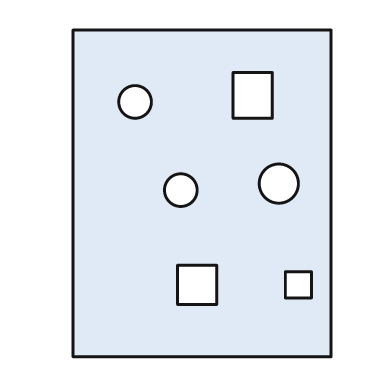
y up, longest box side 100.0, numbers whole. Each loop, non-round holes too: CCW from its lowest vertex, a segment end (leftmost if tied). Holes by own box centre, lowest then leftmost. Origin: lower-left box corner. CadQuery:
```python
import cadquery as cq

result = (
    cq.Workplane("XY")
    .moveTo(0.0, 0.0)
    .lineTo(79.0, 0.0)
    .lineTo(79.0, 100.0)
    .lineTo(0.0, 100.0)
    .close()
    .moveTo(32.0, 16.0)
    .lineTo(44.0, 16.0)
    .lineTo(44.0, 28.0)
    .lineTo(32.0, 28.0)
    .close()
    .moveTo(65.0, 18.0)
    .lineTo(73.0, 18.0)
    .lineTo(73.0, 26.0)
    .lineTo(65.0, 26.0)
    .close()
    .moveTo(33.0, 51.0)
    .circle(5.0)
    .moveTo(63.0, 53.0)
    .circle(6.0)
    .moveTo(19.0, 78.0)
    .circle(5.0)
    .moveTo(49.0, 73.0)
    .lineTo(61.0, 73.0)
    .lineTo(61.0, 87.0)
    .lineTo(49.0, 87.0)
    .close()
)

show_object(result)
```